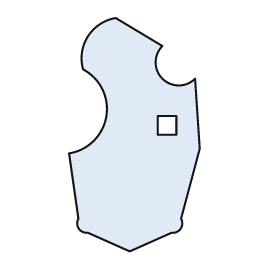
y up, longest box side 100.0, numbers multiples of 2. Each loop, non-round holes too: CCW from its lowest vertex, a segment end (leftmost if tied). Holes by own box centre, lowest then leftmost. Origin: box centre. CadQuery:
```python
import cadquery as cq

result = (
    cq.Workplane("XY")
    .moveTo(-2.0, -50.0)
    .lineTo(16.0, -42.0)
    .threePointArc((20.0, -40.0), (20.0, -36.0))
    .lineTo(28.0, -6.0)
    .lineTo(26.0, 24.0)
    .threePointArc((12.0, 24.0), (12.0, 38.0))
    .lineTo(-8.0, 50.0)
    .threePointArc((-20.0, 42.0), (-22.0, 28.0))
    .threePointArc((-12.0, 8.0), (-28.0, -8.0))
    .lineTo(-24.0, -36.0)
    .threePointArc((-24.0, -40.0), (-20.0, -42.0))
    .close()
    .moveTo(10.0, 0.0)
    .lineTo(18.0, 0.0)
    .lineTo(18.0, 8.0)
    .lineTo(10.0, 8.0)
    .close()
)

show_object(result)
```